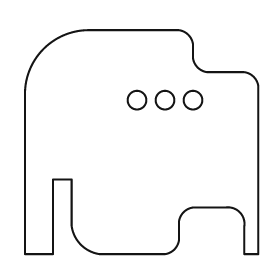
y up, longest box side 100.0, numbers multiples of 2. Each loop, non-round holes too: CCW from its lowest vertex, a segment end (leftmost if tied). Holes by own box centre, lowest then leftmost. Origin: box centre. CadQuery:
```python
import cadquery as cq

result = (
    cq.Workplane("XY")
    .moveTo(-50.0, -48.0)
    .lineTo(-38.0, -48.0)
    .lineTo(-38.0, -16.0)
    .lineTo(-30.0, -16.0)
    .lineTo(-30.0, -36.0)
    .threePointArc((-26.0, -44.0), (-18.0, -48.0))
    .lineTo(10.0, -48.0)
    .threePointArc((14.0, -46.0), (16.0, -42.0))
    .lineTo(16.0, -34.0)
    .threePointArc((18.0, -30.0), (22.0, -28.0))
    .lineTo(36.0, -28.0)
    .threePointArc((42.0, -30.0), (44.0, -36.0))
    .lineTo(44.0, -48.0)
    .lineTo(50.0, -48.0)
    .lineTo(50.0, 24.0)
    .threePointArc((48.0, 28.0), (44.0, 30.0))
    .lineTo(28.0, 30.0)
    .threePointArc((24.0, 32.0), (22.0, 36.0))
    .lineTo(22.0, 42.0)
    .threePointArc((20.0, 46.0), (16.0, 48.0))
    .lineTo(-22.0, 48.0)
    .threePointArc((-42.0, 40.0), (-50.0, 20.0))
    .close()
    .moveTo(-2.0, 18.0)
    .circle(4.0)
    .moveTo(10.0, 18.0)
    .circle(4.0)
    .moveTo(22.0, 18.0)
    .circle(4.0)
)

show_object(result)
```